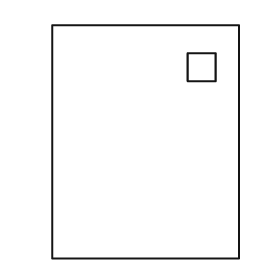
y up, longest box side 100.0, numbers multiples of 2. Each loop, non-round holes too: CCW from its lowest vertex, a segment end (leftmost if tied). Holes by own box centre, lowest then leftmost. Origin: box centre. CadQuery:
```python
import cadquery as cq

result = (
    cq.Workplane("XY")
    .moveTo(-40.0, -50.0)
    .lineTo(40.0, -50.0)
    .lineTo(40.0, 50.0)
    .lineTo(-40.0, 50.0)
    .close()
    .moveTo(18.0, 26.0)
    .lineTo(30.0, 26.0)
    .lineTo(30.0, 38.0)
    .lineTo(18.0, 38.0)
    .close()
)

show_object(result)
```